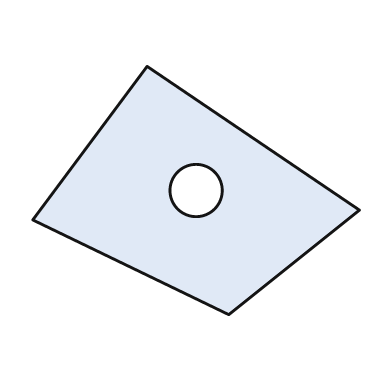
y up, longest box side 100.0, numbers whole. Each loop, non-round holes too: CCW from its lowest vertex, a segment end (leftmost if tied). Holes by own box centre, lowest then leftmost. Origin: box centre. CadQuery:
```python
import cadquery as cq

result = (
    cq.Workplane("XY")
    .moveTo(10.0, -38.0)
    .lineTo(50.0, -6.0)
    .lineTo(-15.0, 38.0)
    .lineTo(-50.0, -9.0)
    .close()
    .moveTo(0.0, 0.0)
    .circle(8.0)
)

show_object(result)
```